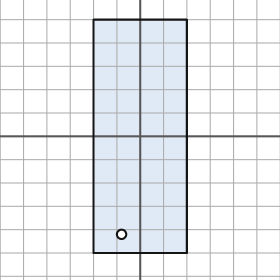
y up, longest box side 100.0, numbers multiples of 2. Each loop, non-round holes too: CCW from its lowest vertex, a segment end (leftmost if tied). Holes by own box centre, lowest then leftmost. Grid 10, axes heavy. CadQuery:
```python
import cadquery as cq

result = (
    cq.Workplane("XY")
    .moveTo(-20.0, -50.0)
    .lineTo(20.0, -50.0)
    .lineTo(20.0, 50.0)
    .lineTo(-20.0, 50.0)
    .close()
    .moveTo(-8.0, -42.0)
    .circle(2.0)
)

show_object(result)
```